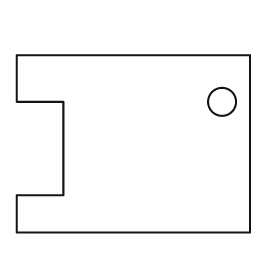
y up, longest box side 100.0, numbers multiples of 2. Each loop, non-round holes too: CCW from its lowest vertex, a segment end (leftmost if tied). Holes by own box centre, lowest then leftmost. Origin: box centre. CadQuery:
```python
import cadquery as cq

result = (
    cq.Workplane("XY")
    .moveTo(-50.0, -38.0)
    .lineTo(50.0, -38.0)
    .lineTo(50.0, 38.0)
    .lineTo(-50.0, 38.0)
    .lineTo(-50.0, 18.0)
    .lineTo(-30.0, 18.0)
    .lineTo(-30.0, -22.0)
    .lineTo(-50.0, -22.0)
    .close()
    .moveTo(38.0, 18.0)
    .circle(6.0)
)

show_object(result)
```